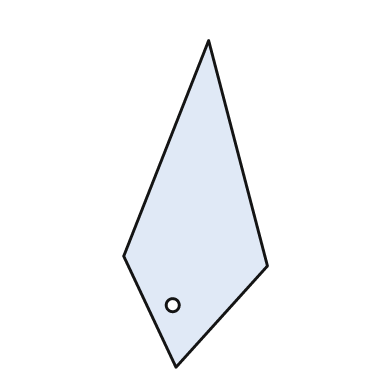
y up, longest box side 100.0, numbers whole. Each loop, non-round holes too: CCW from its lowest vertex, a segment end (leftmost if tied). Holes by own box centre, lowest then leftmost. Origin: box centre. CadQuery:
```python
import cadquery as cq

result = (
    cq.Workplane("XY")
    .moveTo(-6.0, -50.0)
    .lineTo(22.0, -19.0)
    .lineTo(4.0, 50.0)
    .lineTo(-22.0, -16.0)
    .close()
    .moveTo(-7.0, -31.0)
    .circle(2.0)
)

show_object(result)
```